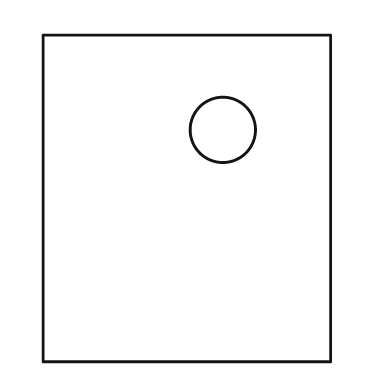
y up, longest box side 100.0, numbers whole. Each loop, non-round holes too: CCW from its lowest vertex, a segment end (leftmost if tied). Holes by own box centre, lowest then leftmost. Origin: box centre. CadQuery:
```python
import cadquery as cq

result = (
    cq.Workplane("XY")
    .moveTo(-44.0, -50.0)
    .lineTo(44.0, -50.0)
    .lineTo(44.0, 50.0)
    .lineTo(-44.0, 50.0)
    .close()
    .moveTo(11.0, 21.0)
    .circle(10.0)
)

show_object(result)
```